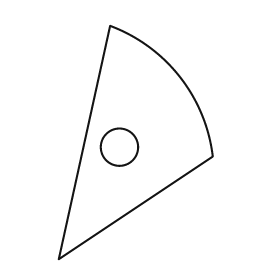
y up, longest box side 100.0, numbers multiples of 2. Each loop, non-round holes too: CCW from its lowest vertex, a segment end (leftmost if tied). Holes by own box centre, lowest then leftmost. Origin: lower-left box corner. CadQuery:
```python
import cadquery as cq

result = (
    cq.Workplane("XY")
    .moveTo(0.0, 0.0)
    .lineTo(66.0, 44.0)
    .threePointArc((52.0, 78.0), (22.0, 100.0))
    .close()
    .moveTo(26.0, 48.0)
    .circle(8.0)
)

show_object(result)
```